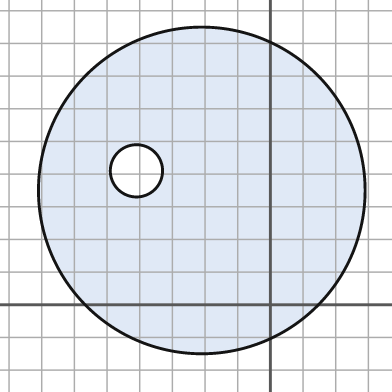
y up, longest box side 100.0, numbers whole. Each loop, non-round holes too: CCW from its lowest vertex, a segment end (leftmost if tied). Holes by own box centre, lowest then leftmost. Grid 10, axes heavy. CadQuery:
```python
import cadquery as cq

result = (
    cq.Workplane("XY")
    .moveTo(-21.0, 35.0)
    .circle(50.0)
    .moveTo(-41.0, 41.0)
    .circle(8.0)
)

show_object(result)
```